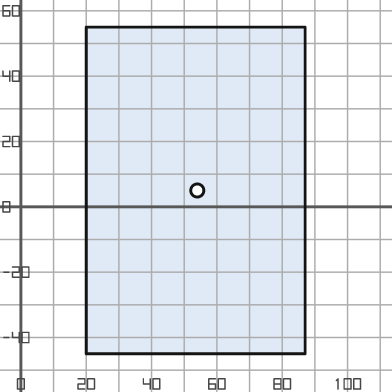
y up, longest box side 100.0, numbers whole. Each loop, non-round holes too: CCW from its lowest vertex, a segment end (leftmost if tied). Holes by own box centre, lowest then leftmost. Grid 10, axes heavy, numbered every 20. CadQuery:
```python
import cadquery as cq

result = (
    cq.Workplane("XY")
    .moveTo(20.0, -45.0)
    .lineTo(87.0, -45.0)
    .lineTo(87.0, 55.0)
    .lineTo(20.0, 55.0)
    .close()
    .moveTo(54.0, 5.0)
    .circle(2.0)
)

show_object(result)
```